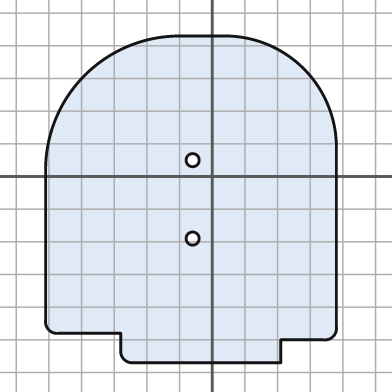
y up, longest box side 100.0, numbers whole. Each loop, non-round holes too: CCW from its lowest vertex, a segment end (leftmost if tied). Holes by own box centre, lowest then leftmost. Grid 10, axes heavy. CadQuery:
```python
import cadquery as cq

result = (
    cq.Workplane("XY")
    .moveTo(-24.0, -57.0)
    .lineTo(21.0, -57.0)
    .lineTo(21.0, -50.0)
    .lineTo(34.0, -50.0)
    .threePointArc((37.0, -49.0), (38.0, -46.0))
    .lineTo(38.0, 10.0)
    .threePointArc((28.0, 33.0), (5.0, 43.0))
    .lineTo(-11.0, 43.0)
    .threePointArc((-39.0, 31.0), (-51.0, 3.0))
    .lineTo(-51.0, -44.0)
    .threePointArc((-50.0, -47.0), (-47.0, -48.0))
    .lineTo(-28.0, -48.0)
    .lineTo(-28.0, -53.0)
    .threePointArc((-27.0, -56.0), (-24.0, -57.0))
    .close()
    .moveTo(-6.0, -19.0)
    .circle(2.0)
    .moveTo(-6.0, 5.0)
    .circle(2.0)
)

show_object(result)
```